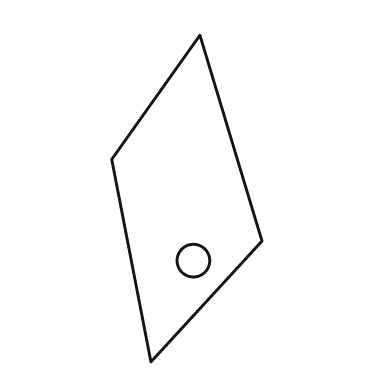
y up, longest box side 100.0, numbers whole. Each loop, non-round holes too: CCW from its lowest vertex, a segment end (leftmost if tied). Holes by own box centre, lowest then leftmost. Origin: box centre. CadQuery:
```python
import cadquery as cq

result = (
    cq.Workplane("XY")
    .moveTo(-11.0, -50.0)
    .lineTo(23.0, -13.0)
    .lineTo(4.0, 50.0)
    .lineTo(-23.0, 12.0)
    .close()
    .moveTo(2.0, -19.0)
    .circle(5.0)
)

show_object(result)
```